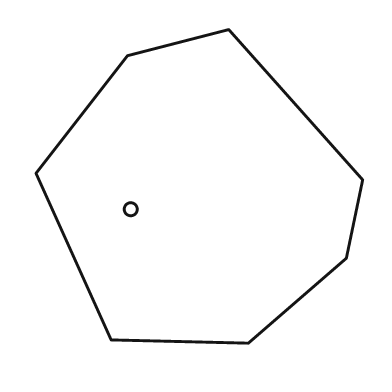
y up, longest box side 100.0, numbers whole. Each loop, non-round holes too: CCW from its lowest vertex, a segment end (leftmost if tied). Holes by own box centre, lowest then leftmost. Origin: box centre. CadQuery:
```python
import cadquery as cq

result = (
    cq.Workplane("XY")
    .moveTo(15.0, -48.0)
    .lineTo(45.0, -22.0)
    .lineTo(50.0, 2.0)
    .lineTo(9.0, 48.0)
    .lineTo(-22.0, 40.0)
    .lineTo(-50.0, 4.0)
    .lineTo(-27.0, -47.0)
    .close()
    .moveTo(-21.0, -7.0)
    .circle(2.0)
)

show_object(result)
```